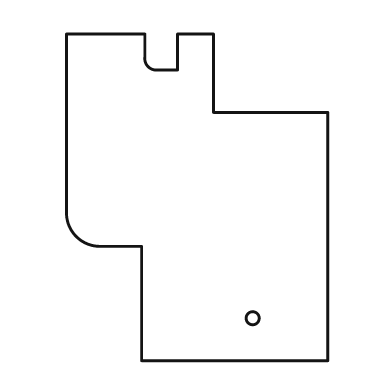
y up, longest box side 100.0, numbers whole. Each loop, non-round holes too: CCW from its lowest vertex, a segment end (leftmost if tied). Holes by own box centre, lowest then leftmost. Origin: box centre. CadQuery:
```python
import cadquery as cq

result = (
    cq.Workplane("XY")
    .moveTo(-17.0, -50.0)
    .lineTo(40.0, -50.0)
    .lineTo(40.0, 26.0)
    .lineTo(5.0, 26.0)
    .lineTo(5.0, 50.0)
    .lineTo(-6.0, 50.0)
    .lineTo(-6.0, 39.0)
    .lineTo(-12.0, 39.0)
    .threePointArc((-15.0, 40.0), (-16.0, 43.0))
    .lineTo(-16.0, 50.0)
    .lineTo(-40.0, 50.0)
    .lineTo(-40.0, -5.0)
    .threePointArc((-37.0, -12.0), (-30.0, -15.0))
    .lineTo(-17.0, -15.0)
    .close()
    .moveTo(17.0, -37.0)
    .circle(2.0)
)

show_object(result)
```